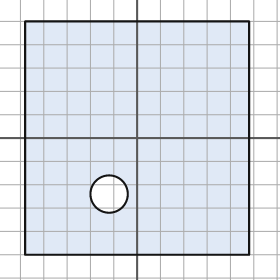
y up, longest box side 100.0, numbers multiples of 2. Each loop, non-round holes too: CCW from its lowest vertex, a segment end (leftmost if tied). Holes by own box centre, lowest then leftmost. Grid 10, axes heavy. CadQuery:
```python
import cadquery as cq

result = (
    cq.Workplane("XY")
    .moveTo(-48.0, -50.0)
    .lineTo(48.0, -50.0)
    .lineTo(48.0, 50.0)
    .lineTo(-48.0, 50.0)
    .close()
    .moveTo(-12.0, -24.0)
    .circle(8.0)
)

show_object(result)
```